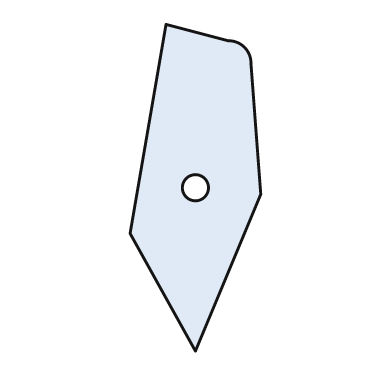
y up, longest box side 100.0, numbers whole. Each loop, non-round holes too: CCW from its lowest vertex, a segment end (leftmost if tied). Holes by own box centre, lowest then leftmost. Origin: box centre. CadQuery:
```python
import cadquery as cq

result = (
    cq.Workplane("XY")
    .moveTo(0.0, -50.0)
    .lineTo(20.0, -2.0)
    .lineTo(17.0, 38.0)
    .threePointArc((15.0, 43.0), (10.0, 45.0))
    .lineTo(-9.0, 50.0)
    .lineTo(-20.0, -14.0)
    .close()
    .moveTo(0.0, 0.0)
    .circle(4.0)
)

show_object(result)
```